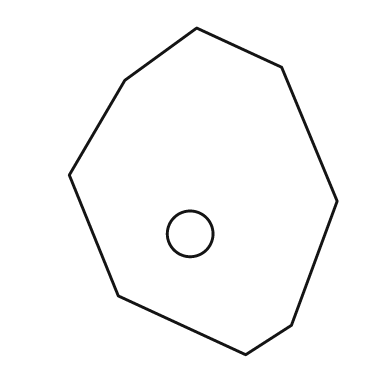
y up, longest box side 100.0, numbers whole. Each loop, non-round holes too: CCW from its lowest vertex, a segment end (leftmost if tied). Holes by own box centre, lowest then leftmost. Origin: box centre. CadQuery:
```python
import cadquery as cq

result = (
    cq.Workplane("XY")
    .moveTo(13.0, -50.0)
    .lineTo(27.0, -41.0)
    .lineTo(41.0, -3.0)
    .lineTo(24.0, 38.0)
    .lineTo(-2.0, 50.0)
    .lineTo(-24.0, 34.0)
    .lineTo(-41.0, 5.0)
    .lineTo(-26.0, -32.0)
    .close()
    .moveTo(-4.0, -13.0)
    .circle(7.0)
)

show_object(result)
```